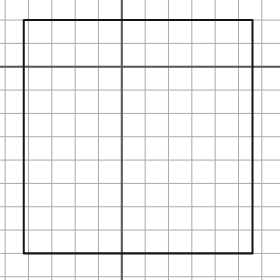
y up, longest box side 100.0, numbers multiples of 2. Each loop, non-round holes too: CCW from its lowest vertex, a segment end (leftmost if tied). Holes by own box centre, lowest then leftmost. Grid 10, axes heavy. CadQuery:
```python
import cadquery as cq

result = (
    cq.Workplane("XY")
    .moveTo(-42.0, -80.0)
    .lineTo(56.0, -80.0)
    .lineTo(56.0, 20.0)
    .lineTo(-42.0, 20.0)
    .close()
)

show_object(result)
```